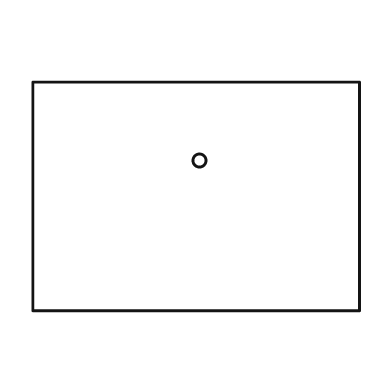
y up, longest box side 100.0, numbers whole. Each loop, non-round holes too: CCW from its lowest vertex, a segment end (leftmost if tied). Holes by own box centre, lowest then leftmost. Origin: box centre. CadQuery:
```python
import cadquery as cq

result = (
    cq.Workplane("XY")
    .moveTo(-50.0, -35.0)
    .lineTo(50.0, -35.0)
    .lineTo(50.0, 35.0)
    .lineTo(-50.0, 35.0)
    .close()
    .moveTo(1.0, 11.0)
    .circle(2.0)
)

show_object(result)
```